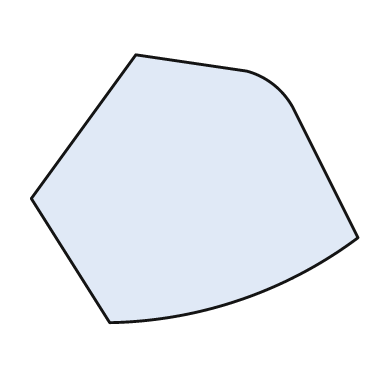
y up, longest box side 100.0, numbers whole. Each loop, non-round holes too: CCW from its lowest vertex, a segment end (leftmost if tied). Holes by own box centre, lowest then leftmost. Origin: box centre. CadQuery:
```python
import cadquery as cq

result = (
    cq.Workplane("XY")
    .moveTo(-26.0, -41.0)
    .threePointArc((14.0, -34.0), (50.0, -15.0))
    .lineTo(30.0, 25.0)
    .threePointArc((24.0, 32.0), (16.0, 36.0))
    .lineTo(-18.0, 41.0)
    .lineTo(-50.0, -3.0)
    .close()
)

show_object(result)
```